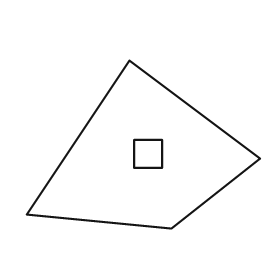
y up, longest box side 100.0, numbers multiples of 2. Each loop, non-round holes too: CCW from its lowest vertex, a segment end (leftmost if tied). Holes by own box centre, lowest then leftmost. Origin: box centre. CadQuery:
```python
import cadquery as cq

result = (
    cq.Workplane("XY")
    .moveTo(12.0, -36.0)
    .lineTo(50.0, -6.0)
    .lineTo(-6.0, 36.0)
    .lineTo(-50.0, -30.0)
    .close()
    .moveTo(-4.0, -10.0)
    .lineTo(8.0, -10.0)
    .lineTo(8.0, 2.0)
    .lineTo(-4.0, 2.0)
    .close()
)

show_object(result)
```